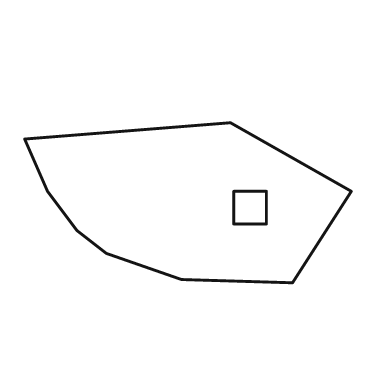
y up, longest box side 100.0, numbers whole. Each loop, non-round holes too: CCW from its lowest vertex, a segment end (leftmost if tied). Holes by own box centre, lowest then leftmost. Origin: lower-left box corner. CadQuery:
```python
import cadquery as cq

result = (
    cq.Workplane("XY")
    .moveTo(82.0, 0.0)
    .lineTo(100.0, 28.0)
    .lineTo(63.0, 49.0)
    .lineTo(0.0, 44.0)
    .lineTo(7.0, 28.0)
    .lineTo(16.0, 16.0)
    .lineTo(25.0, 9.0)
    .lineTo(48.0, 1.0)
    .close()
    .moveTo(64.0, 18.0)
    .lineTo(74.0, 18.0)
    .lineTo(74.0, 28.0)
    .lineTo(64.0, 28.0)
    .close()
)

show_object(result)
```